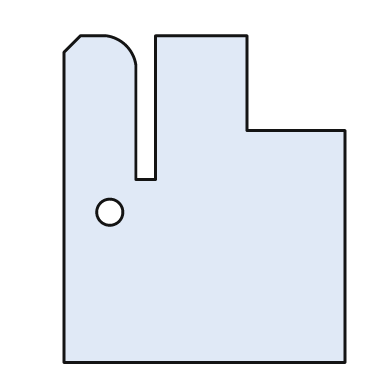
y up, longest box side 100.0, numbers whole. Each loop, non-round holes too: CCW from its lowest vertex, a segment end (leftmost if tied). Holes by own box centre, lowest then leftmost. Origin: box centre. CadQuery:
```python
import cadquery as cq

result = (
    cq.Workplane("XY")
    .moveTo(-43.0, -50.0)
    .lineTo(43.0, -50.0)
    .lineTo(43.0, 21.0)
    .lineTo(13.0, 21.0)
    .lineTo(13.0, 50.0)
    .lineTo(-15.0, 50.0)
    .lineTo(-15.0, 6.0)
    .lineTo(-21.0, 6.0)
    .lineTo(-21.0, 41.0)
    .threePointArc((-24.0, 47.0), (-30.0, 50.0))
    .lineTo(-38.0, 50.0)
    .lineTo(-43.0, 45.0)
    .close()
    .moveTo(-29.0, -4.0)
    .circle(4.0)
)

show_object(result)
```